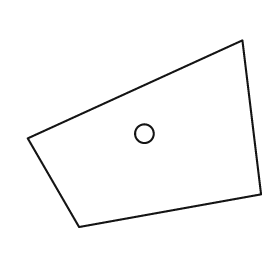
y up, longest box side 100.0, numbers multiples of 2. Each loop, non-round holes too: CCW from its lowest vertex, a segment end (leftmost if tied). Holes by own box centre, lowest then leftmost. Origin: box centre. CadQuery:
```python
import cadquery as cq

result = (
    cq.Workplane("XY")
    .moveTo(-28.0, -40.0)
    .lineTo(50.0, -26.0)
    .lineTo(42.0, 40.0)
    .lineTo(-50.0, -2.0)
    .close()
    .moveTo(0.0, 0.0)
    .circle(4.0)
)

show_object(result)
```